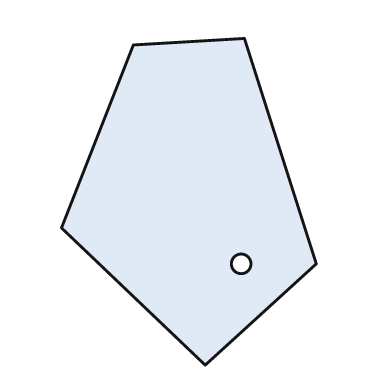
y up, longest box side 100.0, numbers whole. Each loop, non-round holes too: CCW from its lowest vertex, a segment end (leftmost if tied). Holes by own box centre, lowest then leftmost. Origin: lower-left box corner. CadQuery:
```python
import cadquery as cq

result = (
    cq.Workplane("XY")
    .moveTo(44.0, 0.0)
    .lineTo(78.0, 31.0)
    .lineTo(56.0, 100.0)
    .lineTo(22.0, 98.0)
    .lineTo(0.0, 42.0)
    .close()
    .moveTo(55.0, 31.0)
    .circle(3.0)
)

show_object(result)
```